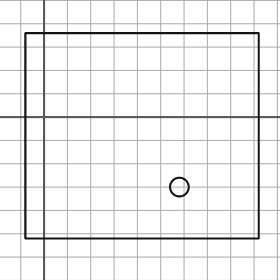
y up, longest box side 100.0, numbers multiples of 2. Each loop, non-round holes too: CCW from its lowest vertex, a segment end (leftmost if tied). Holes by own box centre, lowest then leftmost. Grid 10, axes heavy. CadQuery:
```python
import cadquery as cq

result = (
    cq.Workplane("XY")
    .moveTo(-8.0, -52.0)
    .lineTo(92.0, -52.0)
    .lineTo(92.0, 36.0)
    .lineTo(-8.0, 36.0)
    .close()
    .moveTo(58.0, -30.0)
    .circle(4.0)
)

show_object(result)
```